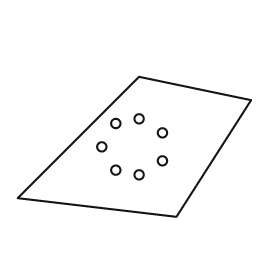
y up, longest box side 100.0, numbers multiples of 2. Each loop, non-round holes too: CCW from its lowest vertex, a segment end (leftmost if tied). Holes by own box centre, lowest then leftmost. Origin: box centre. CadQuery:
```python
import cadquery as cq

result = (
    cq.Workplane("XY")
    .moveTo(18.0, -30.0)
    .lineTo(50.0, 20.0)
    .lineTo(2.0, 30.0)
    .lineTo(-50.0, -22.0)
    .close()
    .moveTo(2.0, -12.0)
    .circle(2.0)
    .moveTo(-8.0, -10.0)
    .circle(2.0)
    .moveTo(12.0, -6.0)
    .circle(2.0)
    .moveTo(-14.0, 0.0)
    .circle(2.0)
    .moveTo(12.0, 6.0)
    .circle(2.0)
    .moveTo(-8.0, 10.0)
    .circle(2.0)
    .moveTo(2.0, 12.0)
    .circle(2.0)
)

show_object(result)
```